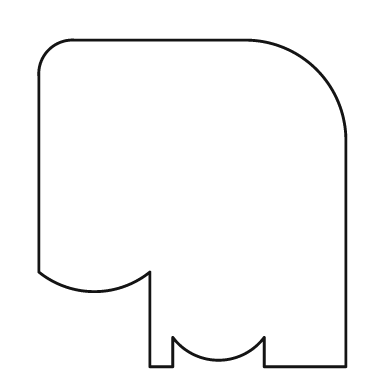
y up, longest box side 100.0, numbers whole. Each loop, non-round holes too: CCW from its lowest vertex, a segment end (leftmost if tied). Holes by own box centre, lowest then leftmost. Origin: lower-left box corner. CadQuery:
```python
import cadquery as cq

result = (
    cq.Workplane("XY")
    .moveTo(34.0, 0.0)
    .lineTo(41.0, 0.0)
    .lineTo(41.0, 9.0)
    .threePointArc((55.0, 2.0), (69.0, 9.0))
    .lineTo(69.0, 0.0)
    .lineTo(94.0, 0.0)
    .lineTo(94.0, 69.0)
    .threePointArc((85.0, 91.0), (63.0, 100.0))
    .lineTo(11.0, 100.0)
    .threePointArc((3.0, 97.0), (0.0, 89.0))
    .lineTo(0.0, 29.0)
    .threePointArc((17.0, 23.0), (34.0, 29.0))
    .close()
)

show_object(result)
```